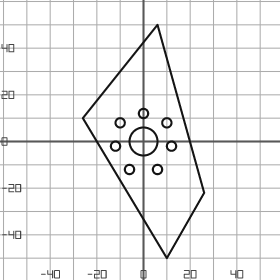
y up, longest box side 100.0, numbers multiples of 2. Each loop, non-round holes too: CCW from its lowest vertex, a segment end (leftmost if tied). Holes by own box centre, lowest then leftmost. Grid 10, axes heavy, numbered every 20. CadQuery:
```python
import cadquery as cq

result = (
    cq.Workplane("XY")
    .moveTo(10.0, -50.0)
    .lineTo(26.0, -22.0)
    .lineTo(6.0, 50.0)
    .lineTo(-26.0, 10.0)
    .close()
    .moveTo(-6.0, -12.0)
    .circle(2.0)
    .moveTo(6.0, -12.0)
    .circle(2.0)
    .moveTo(-12.0, -2.0)
    .circle(2.0)
    .moveTo(12.0, -2.0)
    .circle(2.0)
    .moveTo(0.0, 0.0)
    .circle(6.0)
    .moveTo(-10.0, 8.0)
    .circle(2.0)
    .moveTo(10.0, 8.0)
    .circle(2.0)
    .moveTo(0.0, 12.0)
    .circle(2.0)
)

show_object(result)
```